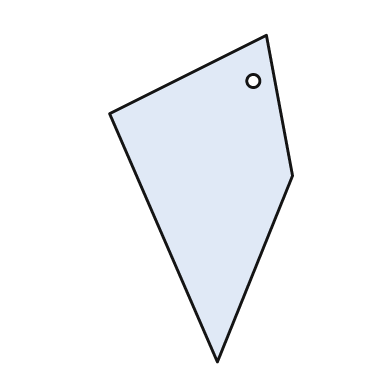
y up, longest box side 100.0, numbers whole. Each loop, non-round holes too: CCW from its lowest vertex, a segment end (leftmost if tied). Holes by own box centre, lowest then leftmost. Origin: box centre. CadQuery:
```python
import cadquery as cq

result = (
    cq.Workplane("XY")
    .moveTo(5.0, -50.0)
    .lineTo(28.0, 7.0)
    .lineTo(20.0, 50.0)
    .lineTo(-28.0, 26.0)
    .close()
    .moveTo(16.0, 36.0)
    .circle(2.0)
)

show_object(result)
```